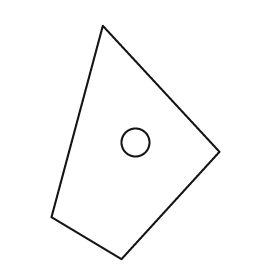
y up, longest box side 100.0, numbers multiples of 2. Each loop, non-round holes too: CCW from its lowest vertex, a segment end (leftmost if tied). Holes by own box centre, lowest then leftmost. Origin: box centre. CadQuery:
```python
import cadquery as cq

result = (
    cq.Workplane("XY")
    .moveTo(-6.0, -50.0)
    .lineTo(36.0, -4.0)
    .lineTo(-14.0, 50.0)
    .lineTo(-36.0, -32.0)
    .close()
    .moveTo(0.0, 0.0)
    .circle(6.0)
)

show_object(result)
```